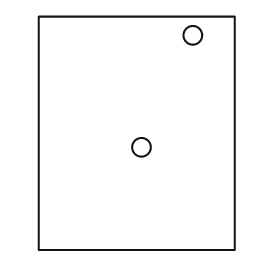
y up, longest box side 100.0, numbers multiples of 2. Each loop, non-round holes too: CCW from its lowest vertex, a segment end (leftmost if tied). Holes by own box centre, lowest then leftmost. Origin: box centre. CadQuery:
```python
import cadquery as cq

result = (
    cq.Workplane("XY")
    .moveTo(-42.0, -50.0)
    .lineTo(42.0, -50.0)
    .lineTo(42.0, 50.0)
    .lineTo(-42.0, 50.0)
    .close()
    .moveTo(2.0, -6.0)
    .circle(4.0)
    .moveTo(24.0, 42.0)
    .circle(4.0)
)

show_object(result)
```